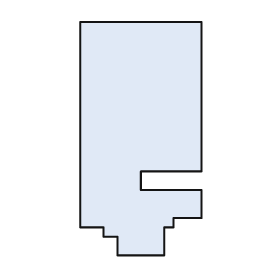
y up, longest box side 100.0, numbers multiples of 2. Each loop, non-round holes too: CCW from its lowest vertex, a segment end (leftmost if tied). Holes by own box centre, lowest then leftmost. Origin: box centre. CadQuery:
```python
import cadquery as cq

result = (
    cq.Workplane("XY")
    .moveTo(-10.0, -50.0)
    .lineTo(10.0, -50.0)
    .lineTo(10.0, -38.0)
    .lineTo(14.0, -38.0)
    .lineTo(14.0, -34.0)
    .lineTo(26.0, -34.0)
    .lineTo(26.0, -22.0)
    .lineTo(0.0, -22.0)
    .lineTo(0.0, -14.0)
    .lineTo(26.0, -14.0)
    .lineTo(26.0, 50.0)
    .lineTo(-26.0, 50.0)
    .lineTo(-26.0, -38.0)
    .lineTo(-16.0, -38.0)
    .lineTo(-16.0, -42.0)
    .lineTo(-10.0, -42.0)
    .close()
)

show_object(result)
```